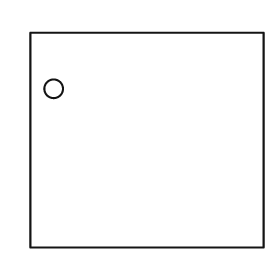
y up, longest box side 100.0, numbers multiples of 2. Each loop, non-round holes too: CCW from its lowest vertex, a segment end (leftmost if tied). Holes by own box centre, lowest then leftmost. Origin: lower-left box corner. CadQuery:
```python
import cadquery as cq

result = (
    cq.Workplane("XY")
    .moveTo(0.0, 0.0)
    .lineTo(100.0, 0.0)
    .lineTo(100.0, 92.0)
    .lineTo(0.0, 92.0)
    .close()
    .moveTo(10.0, 68.0)
    .circle(4.0)
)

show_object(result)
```